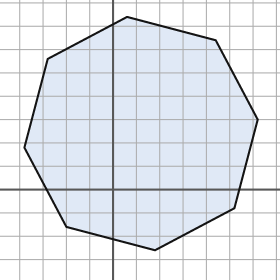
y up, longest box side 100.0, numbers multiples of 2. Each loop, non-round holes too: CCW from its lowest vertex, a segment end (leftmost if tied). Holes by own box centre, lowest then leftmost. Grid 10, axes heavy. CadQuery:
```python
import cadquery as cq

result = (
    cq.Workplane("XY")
    .moveTo(18.0, -26.0)
    .lineTo(52.0, -8.0)
    .lineTo(62.0, 30.0)
    .lineTo(44.0, 64.0)
    .lineTo(6.0, 74.0)
    .lineTo(-28.0, 56.0)
    .lineTo(-38.0, 18.0)
    .lineTo(-20.0, -16.0)
    .close()
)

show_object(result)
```